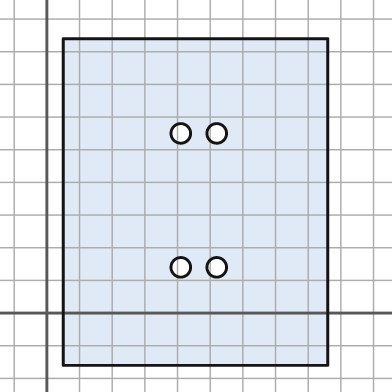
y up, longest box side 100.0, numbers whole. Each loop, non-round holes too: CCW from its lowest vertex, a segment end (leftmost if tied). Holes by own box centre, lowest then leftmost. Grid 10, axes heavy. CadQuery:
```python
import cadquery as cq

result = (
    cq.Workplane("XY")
    .moveTo(5.0, -16.0)
    .lineTo(86.0, -16.0)
    .lineTo(86.0, 84.0)
    .lineTo(5.0, 84.0)
    .close()
    .moveTo(41.0, 14.0)
    .circle(3.0)
    .moveTo(52.0, 14.0)
    .circle(3.0)
    .moveTo(41.0, 55.0)
    .circle(3.0)
    .moveTo(52.0, 55.0)
    .circle(3.0)
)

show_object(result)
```